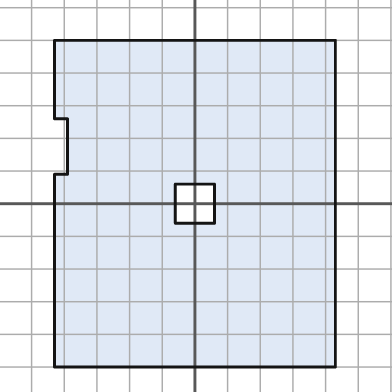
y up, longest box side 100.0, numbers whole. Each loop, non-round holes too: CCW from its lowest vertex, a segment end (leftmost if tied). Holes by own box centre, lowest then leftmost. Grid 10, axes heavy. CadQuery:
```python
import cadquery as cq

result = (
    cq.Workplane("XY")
    .moveTo(-43.0, -50.0)
    .lineTo(43.0, -50.0)
    .lineTo(43.0, 50.0)
    .lineTo(-43.0, 50.0)
    .lineTo(-43.0, 26.0)
    .lineTo(-39.0, 26.0)
    .lineTo(-39.0, 9.0)
    .lineTo(-43.0, 9.0)
    .close()
    .moveTo(-6.0, -6.0)
    .lineTo(6.0, -6.0)
    .lineTo(6.0, 6.0)
    .lineTo(-6.0, 6.0)
    .close()
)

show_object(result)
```